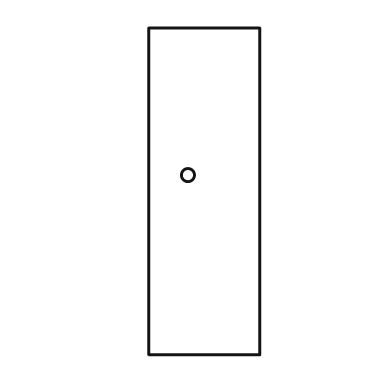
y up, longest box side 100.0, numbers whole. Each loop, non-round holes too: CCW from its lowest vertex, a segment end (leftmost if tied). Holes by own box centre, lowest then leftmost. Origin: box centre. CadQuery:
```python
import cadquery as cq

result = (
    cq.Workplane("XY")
    .moveTo(-17.0, -50.0)
    .lineTo(17.0, -50.0)
    .lineTo(17.0, 50.0)
    .lineTo(-17.0, 50.0)
    .close()
    .moveTo(-5.0, 5.0)
    .circle(2.0)
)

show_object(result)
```